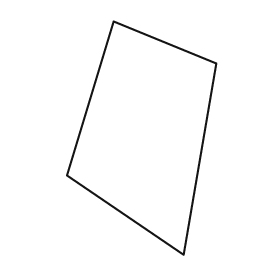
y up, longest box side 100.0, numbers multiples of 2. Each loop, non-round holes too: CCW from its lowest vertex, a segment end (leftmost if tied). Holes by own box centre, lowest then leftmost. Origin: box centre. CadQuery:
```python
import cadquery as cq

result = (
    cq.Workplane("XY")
    .moveTo(18.0, -50.0)
    .lineTo(32.0, 32.0)
    .lineTo(-12.0, 50.0)
    .lineTo(-32.0, -16.0)
    .close()
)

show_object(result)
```